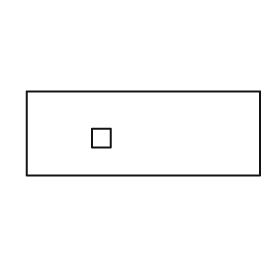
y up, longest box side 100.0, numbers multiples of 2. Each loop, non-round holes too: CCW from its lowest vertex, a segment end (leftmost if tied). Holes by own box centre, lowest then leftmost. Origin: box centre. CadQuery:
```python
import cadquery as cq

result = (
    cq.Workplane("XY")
    .moveTo(-50.0, -18.0)
    .lineTo(50.0, -18.0)
    .lineTo(50.0, 18.0)
    .lineTo(-50.0, 18.0)
    .close()
    .moveTo(-22.0, -6.0)
    .lineTo(-14.0, -6.0)
    .lineTo(-14.0, 2.0)
    .lineTo(-22.0, 2.0)
    .close()
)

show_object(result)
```